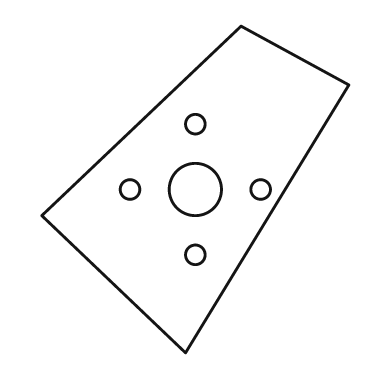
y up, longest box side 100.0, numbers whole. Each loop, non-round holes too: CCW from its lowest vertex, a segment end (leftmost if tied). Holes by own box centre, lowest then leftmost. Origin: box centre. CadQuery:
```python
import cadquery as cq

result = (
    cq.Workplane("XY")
    .moveTo(-3.0, -50.0)
    .lineTo(47.0, 32.0)
    .lineTo(14.0, 50.0)
    .lineTo(-47.0, -8.0)
    .close()
    .moveTo(0.0, -20.0)
    .circle(3.0)
    .moveTo(-20.0, 0.0)
    .circle(3.0)
    .moveTo(0.0, 0.0)
    .circle(8.0)
    .moveTo(20.0, 0.0)
    .circle(3.0)
    .moveTo(0.0, 20.0)
    .circle(3.0)
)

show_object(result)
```